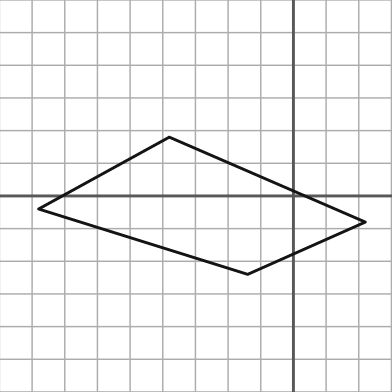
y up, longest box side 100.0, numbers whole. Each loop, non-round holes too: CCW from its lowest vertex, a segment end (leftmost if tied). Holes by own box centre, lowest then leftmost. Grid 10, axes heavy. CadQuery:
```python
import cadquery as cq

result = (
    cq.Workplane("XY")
    .moveTo(-14.0, -24.0)
    .lineTo(22.0, -8.0)
    .lineTo(-38.0, 18.0)
    .lineTo(-78.0, -4.0)
    .close()
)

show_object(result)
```